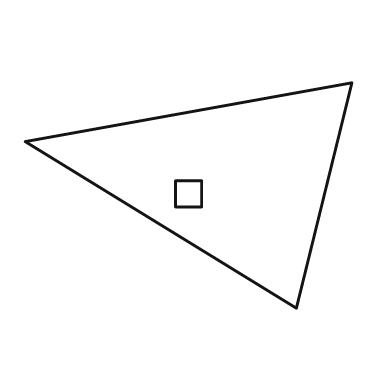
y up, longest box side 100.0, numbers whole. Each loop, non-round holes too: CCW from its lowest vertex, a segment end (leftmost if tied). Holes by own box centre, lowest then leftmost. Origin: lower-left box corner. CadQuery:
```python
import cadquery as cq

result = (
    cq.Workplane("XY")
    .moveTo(83.0, 0.0)
    .lineTo(100.0, 69.0)
    .lineTo(0.0, 51.0)
    .close()
    .moveTo(46.0, 31.0)
    .lineTo(54.0, 31.0)
    .lineTo(54.0, 39.0)
    .lineTo(46.0, 39.0)
    .close()
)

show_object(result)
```